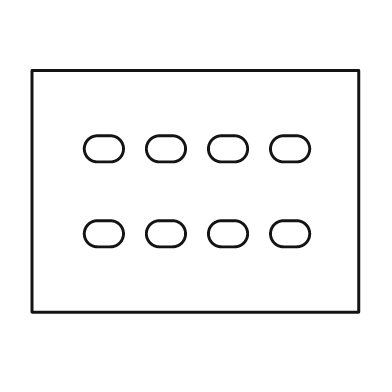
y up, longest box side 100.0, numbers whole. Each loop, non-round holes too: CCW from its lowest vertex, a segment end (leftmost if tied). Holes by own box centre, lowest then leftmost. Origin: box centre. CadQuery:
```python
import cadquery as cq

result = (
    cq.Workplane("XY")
    .moveTo(-50.0, -37.0)
    .lineTo(50.0, -37.0)
    .lineTo(50.0, 37.0)
    .lineTo(-50.0, 37.0)
    .close()
    .moveTo(-30.0, -17.0)
    .lineTo(-26.0, -17.0)
    .threePointArc((-22.0, -13.0), (-26.0, -9.0))
    .lineTo(-30.0, -9.0)
    .threePointArc((-34.0, -13.0), (-30.0, -17.0))
    .close()
    .moveTo(-11.0, -17.0)
    .lineTo(-7.0, -17.0)
    .threePointArc((-3.0, -13.0), (-7.0, -9.0))
    .lineTo(-11.0, -9.0)
    .threePointArc((-15.0, -13.0), (-11.0, -17.0))
    .close()
    .moveTo(8.0, -17.0)
    .lineTo(12.0, -17.0)
    .threePointArc((16.0, -13.0), (12.0, -9.0))
    .lineTo(8.0, -9.0)
    .threePointArc((4.0, -13.0), (8.0, -17.0))
    .close()
    .moveTo(27.0, -17.0)
    .lineTo(31.0, -17.0)
    .threePointArc((35.0, -13.0), (31.0, -9.0))
    .lineTo(27.0, -9.0)
    .threePointArc((23.0, -13.0), (27.0, -17.0))
    .close()
    .moveTo(-30.0, 9.0)
    .lineTo(-26.0, 9.0)
    .threePointArc((-22.0, 13.0), (-26.0, 17.0))
    .lineTo(-30.0, 17.0)
    .threePointArc((-34.0, 13.0), (-30.0, 9.0))
    .close()
    .moveTo(-11.0, 9.0)
    .lineTo(-7.0, 9.0)
    .threePointArc((-3.0, 13.0), (-7.0, 17.0))
    .lineTo(-11.0, 17.0)
    .threePointArc((-15.0, 13.0), (-11.0, 9.0))
    .close()
    .moveTo(8.0, 9.0)
    .lineTo(12.0, 9.0)
    .threePointArc((16.0, 13.0), (12.0, 17.0))
    .lineTo(8.0, 17.0)
    .threePointArc((4.0, 13.0), (8.0, 9.0))
    .close()
    .moveTo(27.0, 9.0)
    .lineTo(31.0, 9.0)
    .threePointArc((35.0, 13.0), (31.0, 17.0))
    .lineTo(27.0, 17.0)
    .threePointArc((23.0, 13.0), (27.0, 9.0))
    .close()
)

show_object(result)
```